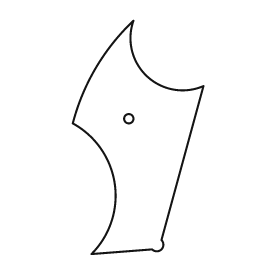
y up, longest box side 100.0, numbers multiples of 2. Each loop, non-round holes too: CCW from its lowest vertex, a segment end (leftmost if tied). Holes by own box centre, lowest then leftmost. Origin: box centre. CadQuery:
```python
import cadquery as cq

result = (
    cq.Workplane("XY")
    .moveTo(-20.0, -50.0)
    .lineTo(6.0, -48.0)
    .threePointArc((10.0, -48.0), (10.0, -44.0))
    .lineTo(28.0, 22.0)
    .threePointArc((4.0, 26.0), (-2.0, 50.0))
    .threePointArc((-18.0, 30.0), (-28.0, 6.0))
    .threePointArc((-10.0, -20.0), (-20.0, -50.0))
    .close()
    .moveTo(-4.0, 8.0)
    .circle(2.0)
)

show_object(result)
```